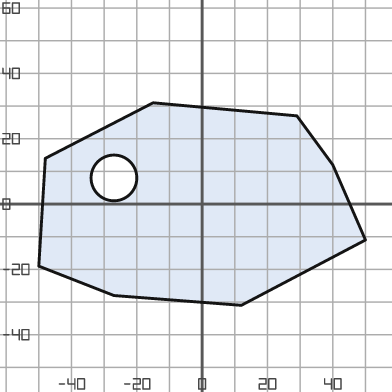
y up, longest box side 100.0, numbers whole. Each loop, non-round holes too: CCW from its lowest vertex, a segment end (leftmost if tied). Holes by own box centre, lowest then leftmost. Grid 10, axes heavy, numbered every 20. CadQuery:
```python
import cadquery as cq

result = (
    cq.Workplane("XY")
    .moveTo(12.0, -31.0)
    .lineTo(50.0, -11.0)
    .lineTo(40.0, 12.0)
    .lineTo(29.0, 27.0)
    .lineTo(-15.0, 31.0)
    .lineTo(-48.0, 14.0)
    .lineTo(-50.0, -19.0)
    .lineTo(-27.0, -28.0)
    .close()
    .moveTo(-27.0, 8.0)
    .circle(7.0)
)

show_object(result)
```